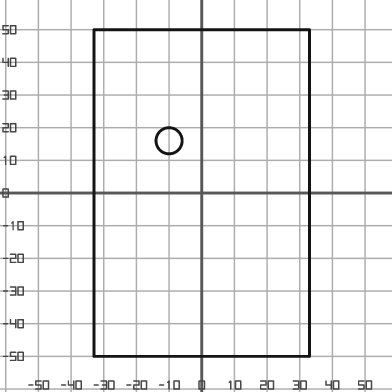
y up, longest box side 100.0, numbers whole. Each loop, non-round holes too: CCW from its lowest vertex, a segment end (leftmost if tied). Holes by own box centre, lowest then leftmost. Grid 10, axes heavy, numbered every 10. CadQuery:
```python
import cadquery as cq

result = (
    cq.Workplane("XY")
    .moveTo(-33.0, -50.0)
    .lineTo(33.0, -50.0)
    .lineTo(33.0, 50.0)
    .lineTo(-33.0, 50.0)
    .close()
    .moveTo(-10.0, 16.0)
    .circle(4.0)
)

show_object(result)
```